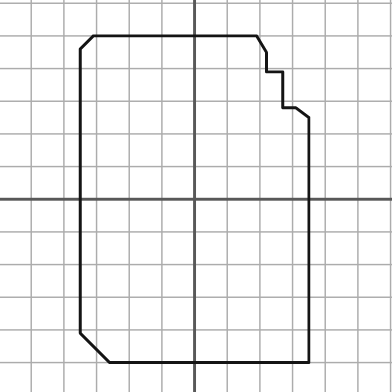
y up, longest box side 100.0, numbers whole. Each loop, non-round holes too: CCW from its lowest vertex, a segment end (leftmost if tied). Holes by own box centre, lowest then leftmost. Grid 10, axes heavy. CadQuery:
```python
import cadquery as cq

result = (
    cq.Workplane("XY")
    .moveTo(-26.0, -50.0)
    .lineTo(35.0, -50.0)
    .lineTo(35.0, 25.0)
    .lineTo(31.0, 28.0)
    .lineTo(27.0, 28.0)
    .lineTo(27.0, 39.0)
    .lineTo(22.0, 39.0)
    .lineTo(22.0, 45.0)
    .lineTo(19.0, 50.0)
    .lineTo(-31.0, 50.0)
    .lineTo(-35.0, 46.0)
    .lineTo(-35.0, -41.0)
    .close()
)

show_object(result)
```